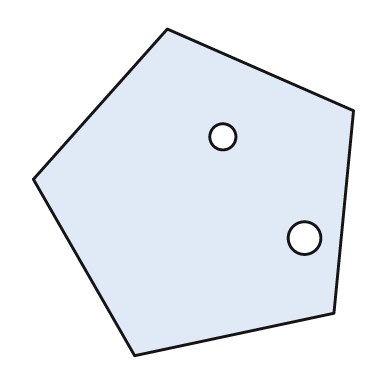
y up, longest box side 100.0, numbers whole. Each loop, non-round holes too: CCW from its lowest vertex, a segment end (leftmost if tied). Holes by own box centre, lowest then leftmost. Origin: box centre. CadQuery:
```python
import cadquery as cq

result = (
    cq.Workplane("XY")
    .moveTo(-18.0, -50.0)
    .lineTo(43.0, -37.0)
    .lineTo(49.0, 25.0)
    .lineTo(-8.0, 50.0)
    .lineTo(-49.0, 4.0)
    .close()
    .moveTo(34.0, -14.0)
    .circle(5.0)
    .moveTo(9.0, 17.0)
    .circle(4.0)
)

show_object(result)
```